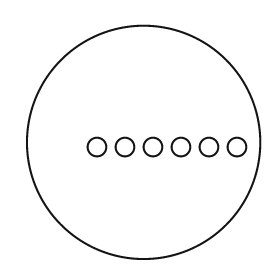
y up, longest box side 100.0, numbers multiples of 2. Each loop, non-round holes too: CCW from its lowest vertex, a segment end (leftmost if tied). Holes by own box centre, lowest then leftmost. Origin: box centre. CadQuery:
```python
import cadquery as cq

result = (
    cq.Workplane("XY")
    .moveTo(0.0, 0.0)
    .circle(50.0)
    .moveTo(-20.0, -2.0)
    .circle(4.0)
    .moveTo(-8.0, -2.0)
    .circle(4.0)
    .moveTo(4.0, -2.0)
    .circle(4.0)
    .moveTo(16.0, -2.0)
    .circle(4.0)
    .moveTo(28.0, -2.0)
    .circle(4.0)
    .moveTo(40.0, -2.0)
    .circle(4.0)
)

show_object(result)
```